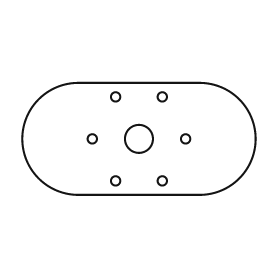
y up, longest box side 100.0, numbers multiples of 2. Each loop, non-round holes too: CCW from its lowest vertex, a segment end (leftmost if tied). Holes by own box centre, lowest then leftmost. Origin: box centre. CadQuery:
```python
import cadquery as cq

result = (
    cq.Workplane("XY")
    .moveTo(-26.0, -24.0)
    .lineTo(26.0, -24.0)
    .threePointArc((50.0, 0.0), (26.0, 24.0))
    .lineTo(-26.0, 24.0)
    .threePointArc((-50.0, 0.0), (-26.0, -24.0))
    .close()
    .moveTo(-10.0, -18.0)
    .circle(2.0)
    .moveTo(10.0, -18.0)
    .circle(2.0)
    .moveTo(-20.0, 0.0)
    .circle(2.0)
    .moveTo(0.0, 0.0)
    .circle(6.0)
    .moveTo(20.0, 0.0)
    .circle(2.0)
    .moveTo(-10.0, 18.0)
    .circle(2.0)
    .moveTo(10.0, 18.0)
    .circle(2.0)
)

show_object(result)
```